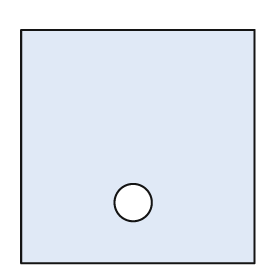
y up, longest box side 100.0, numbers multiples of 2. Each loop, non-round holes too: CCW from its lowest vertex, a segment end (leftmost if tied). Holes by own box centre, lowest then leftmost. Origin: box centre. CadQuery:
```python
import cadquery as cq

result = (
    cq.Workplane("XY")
    .moveTo(-50.0, -50.0)
    .lineTo(50.0, -50.0)
    .lineTo(50.0, 50.0)
    .lineTo(-50.0, 50.0)
    .close()
    .moveTo(-2.0, -24.0)
    .circle(8.0)
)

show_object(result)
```